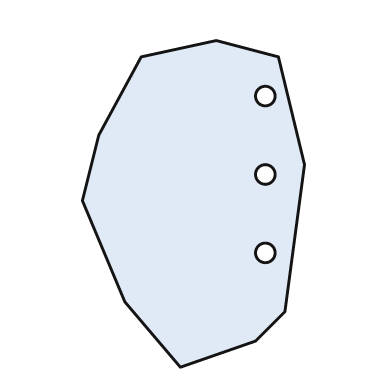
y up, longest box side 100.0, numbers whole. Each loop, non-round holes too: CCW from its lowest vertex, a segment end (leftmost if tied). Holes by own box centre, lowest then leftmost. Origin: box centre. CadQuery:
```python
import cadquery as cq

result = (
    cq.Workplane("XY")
    .moveTo(-4.0, -50.0)
    .lineTo(19.0, -42.0)
    .lineTo(28.0, -33.0)
    .lineTo(34.0, 12.0)
    .lineTo(26.0, 45.0)
    .lineTo(7.0, 50.0)
    .lineTo(-16.0, 45.0)
    .lineTo(-29.0, 21.0)
    .lineTo(-34.0, 1.0)
    .lineTo(-21.0, -30.0)
    .close()
    .moveTo(22.0, -15.0)
    .circle(3.0)
    .moveTo(22.0, 9.0)
    .circle(3.0)
    .moveTo(22.0, 33.0)
    .circle(3.0)
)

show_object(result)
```